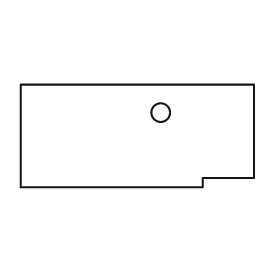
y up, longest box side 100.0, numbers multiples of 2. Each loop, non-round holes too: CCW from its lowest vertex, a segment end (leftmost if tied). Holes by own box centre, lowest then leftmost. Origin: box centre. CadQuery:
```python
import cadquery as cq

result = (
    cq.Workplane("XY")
    .moveTo(-50.0, -22.0)
    .lineTo(28.0, -22.0)
    .lineTo(28.0, -18.0)
    .lineTo(50.0, -18.0)
    .lineTo(50.0, 22.0)
    .lineTo(-50.0, 22.0)
    .close()
    .moveTo(10.0, 10.0)
    .circle(4.0)
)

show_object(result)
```